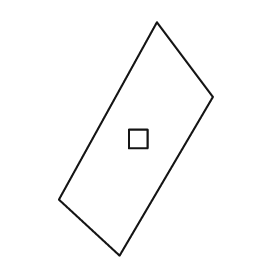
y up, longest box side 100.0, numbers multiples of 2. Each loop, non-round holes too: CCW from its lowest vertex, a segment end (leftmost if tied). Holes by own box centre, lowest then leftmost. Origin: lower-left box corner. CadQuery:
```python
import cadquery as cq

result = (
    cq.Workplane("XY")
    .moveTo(26.0, 0.0)
    .lineTo(66.0, 68.0)
    .lineTo(42.0, 100.0)
    .lineTo(0.0, 24.0)
    .close()
    .moveTo(30.0, 46.0)
    .lineTo(38.0, 46.0)
    .lineTo(38.0, 54.0)
    .lineTo(30.0, 54.0)
    .close()
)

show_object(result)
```